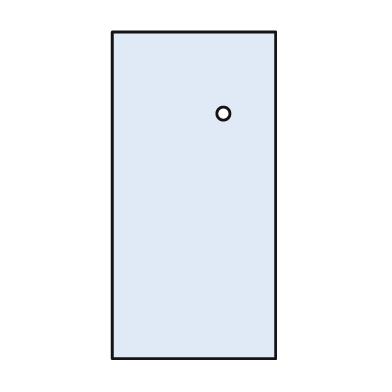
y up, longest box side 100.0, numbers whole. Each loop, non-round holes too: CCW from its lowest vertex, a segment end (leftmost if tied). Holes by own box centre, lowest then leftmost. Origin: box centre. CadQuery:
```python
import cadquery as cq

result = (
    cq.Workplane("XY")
    .moveTo(-25.0, -50.0)
    .lineTo(25.0, -50.0)
    .lineTo(25.0, 50.0)
    .lineTo(-25.0, 50.0)
    .close()
    .moveTo(9.0, 25.0)
    .circle(2.0)
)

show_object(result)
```